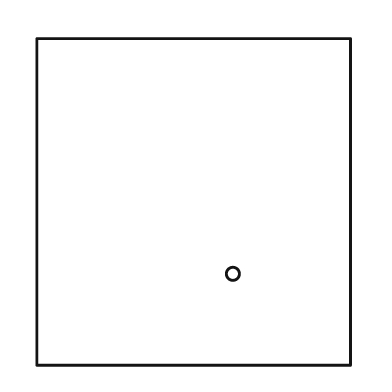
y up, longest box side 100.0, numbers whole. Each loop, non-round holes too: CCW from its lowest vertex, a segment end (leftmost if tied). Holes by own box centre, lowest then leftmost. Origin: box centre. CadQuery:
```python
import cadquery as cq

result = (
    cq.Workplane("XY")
    .moveTo(-48.0, -50.0)
    .lineTo(48.0, -50.0)
    .lineTo(48.0, 50.0)
    .lineTo(-48.0, 50.0)
    .close()
    .moveTo(12.0, -22.0)
    .circle(2.0)
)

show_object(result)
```